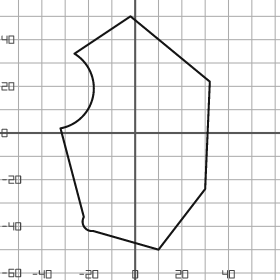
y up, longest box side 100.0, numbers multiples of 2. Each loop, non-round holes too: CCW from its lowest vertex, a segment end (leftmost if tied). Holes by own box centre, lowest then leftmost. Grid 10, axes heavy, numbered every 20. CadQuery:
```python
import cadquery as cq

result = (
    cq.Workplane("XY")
    .moveTo(10.0, -50.0)
    .lineTo(30.0, -24.0)
    .lineTo(32.0, 22.0)
    .lineTo(-2.0, 50.0)
    .lineTo(-26.0, 34.0)
    .threePointArc((-18.0, 16.0), (-32.0, 2.0))
    .lineTo(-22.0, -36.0)
    .threePointArc((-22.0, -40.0), (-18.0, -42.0))
    .close()
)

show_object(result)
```